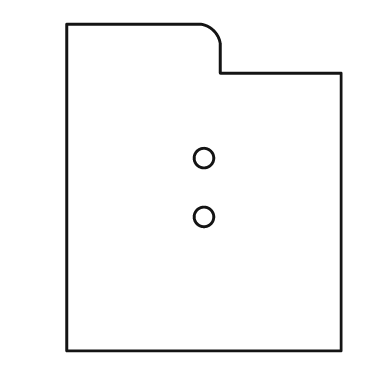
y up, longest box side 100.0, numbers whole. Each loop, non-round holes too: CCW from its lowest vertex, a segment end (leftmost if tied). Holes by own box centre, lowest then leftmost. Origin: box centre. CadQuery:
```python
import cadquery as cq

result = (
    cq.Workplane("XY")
    .moveTo(-42.0, -50.0)
    .lineTo(42.0, -50.0)
    .lineTo(42.0, 35.0)
    .lineTo(5.0, 35.0)
    .lineTo(5.0, 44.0)
    .threePointArc((3.0, 48.0), (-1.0, 50.0))
    .lineTo(-42.0, 50.0)
    .close()
    .moveTo(0.0, -9.0)
    .circle(3.0)
    .moveTo(0.0, 9.0)
    .circle(3.0)
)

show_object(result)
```